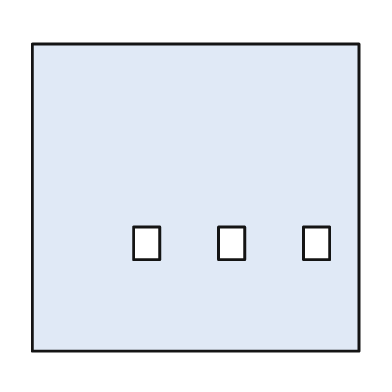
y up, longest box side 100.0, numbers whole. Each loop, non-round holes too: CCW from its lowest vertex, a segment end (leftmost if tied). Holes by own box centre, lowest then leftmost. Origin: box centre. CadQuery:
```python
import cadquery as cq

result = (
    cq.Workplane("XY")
    .moveTo(-50.0, -47.0)
    .lineTo(50.0, -47.0)
    .lineTo(50.0, 47.0)
    .lineTo(-50.0, 47.0)
    .close()
    .moveTo(-19.0, -19.0)
    .lineTo(-11.0, -19.0)
    .lineTo(-11.0, -9.0)
    .lineTo(-19.0, -9.0)
    .close()
    .moveTo(7.0, -19.0)
    .lineTo(15.0, -19.0)
    .lineTo(15.0, -9.0)
    .lineTo(7.0, -9.0)
    .close()
    .moveTo(33.0, -19.0)
    .lineTo(41.0, -19.0)
    .lineTo(41.0, -9.0)
    .lineTo(33.0, -9.0)
    .close()
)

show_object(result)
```